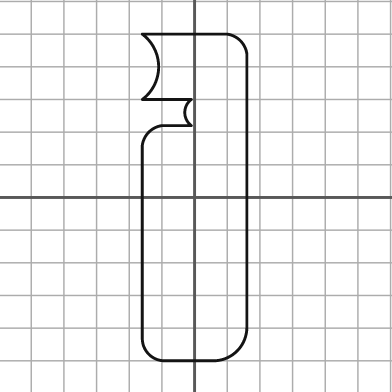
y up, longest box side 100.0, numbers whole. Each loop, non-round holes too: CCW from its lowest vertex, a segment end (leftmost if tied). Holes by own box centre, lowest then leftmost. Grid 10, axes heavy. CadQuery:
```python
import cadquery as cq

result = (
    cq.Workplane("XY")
    .moveTo(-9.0, -50.0)
    .lineTo(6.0, -50.0)
    .threePointArc((13.0, -47.0), (16.0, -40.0))
    .lineTo(16.0, 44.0)
    .threePointArc((14.0, 48.0), (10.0, 50.0))
    .lineTo(-16.0, 50.0)
    .threePointArc((-11.0, 40.0), (-16.0, 30.0))
    .lineTo(-1.0, 30.0)
    .threePointArc((-3.0, 26.0), (-1.0, 22.0))
    .lineTo(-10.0, 22.0)
    .threePointArc((-14.0, 20.0), (-16.0, 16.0))
    .lineTo(-16.0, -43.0)
    .threePointArc((-14.0, -48.0), (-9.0, -50.0))
    .close()
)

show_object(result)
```